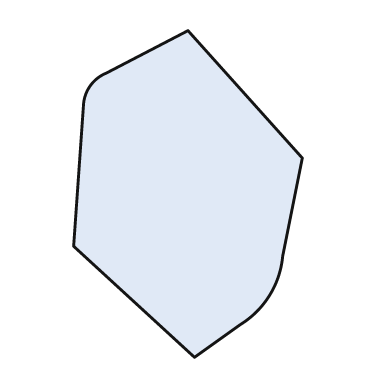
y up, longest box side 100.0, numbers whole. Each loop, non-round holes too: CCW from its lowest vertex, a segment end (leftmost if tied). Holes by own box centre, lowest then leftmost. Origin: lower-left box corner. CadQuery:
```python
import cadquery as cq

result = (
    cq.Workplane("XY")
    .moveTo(37.0, 0.0)
    .lineTo(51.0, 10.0)
    .threePointArc((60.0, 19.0), (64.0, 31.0))
    .lineTo(70.0, 61.0)
    .lineTo(35.0, 100.0)
    .lineTo(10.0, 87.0)
    .threePointArc((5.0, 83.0), (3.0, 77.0))
    .lineTo(0.0, 34.0)
    .close()
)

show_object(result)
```